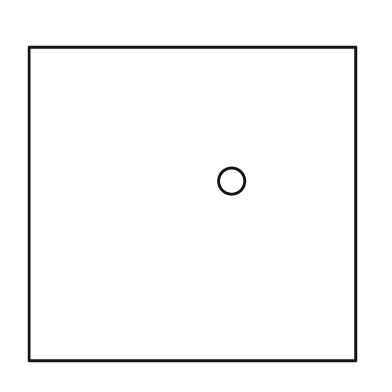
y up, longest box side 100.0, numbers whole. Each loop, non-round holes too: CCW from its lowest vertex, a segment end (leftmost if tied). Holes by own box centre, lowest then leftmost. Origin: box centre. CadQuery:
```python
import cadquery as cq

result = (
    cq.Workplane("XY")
    .moveTo(-50.0, -48.0)
    .lineTo(50.0, -48.0)
    .lineTo(50.0, 48.0)
    .lineTo(-50.0, 48.0)
    .close()
    .moveTo(12.0, 7.0)
    .circle(4.0)
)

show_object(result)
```